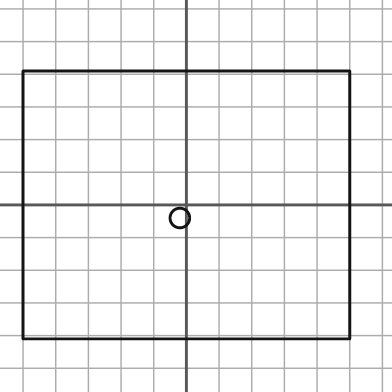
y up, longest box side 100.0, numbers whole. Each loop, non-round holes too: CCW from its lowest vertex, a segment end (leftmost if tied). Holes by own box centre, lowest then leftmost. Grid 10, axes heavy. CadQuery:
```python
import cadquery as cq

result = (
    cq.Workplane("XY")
    .moveTo(-50.0, -41.0)
    .lineTo(50.0, -41.0)
    .lineTo(50.0, 41.0)
    .lineTo(-50.0, 41.0)
    .close()
    .moveTo(-2.0, -4.0)
    .circle(3.0)
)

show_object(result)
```